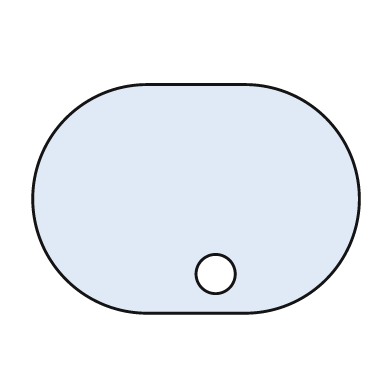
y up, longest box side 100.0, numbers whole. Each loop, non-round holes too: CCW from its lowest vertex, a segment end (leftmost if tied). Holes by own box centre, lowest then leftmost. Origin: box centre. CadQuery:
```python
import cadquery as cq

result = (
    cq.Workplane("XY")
    .moveTo(-15.0, -35.0)
    .lineTo(15.0, -35.0)
    .threePointArc((50.0, 0.0), (15.0, 35.0))
    .lineTo(-15.0, 35.0)
    .threePointArc((-50.0, 0.0), (-15.0, -35.0))
    .close()
    .moveTo(6.0, -23.0)
    .circle(6.0)
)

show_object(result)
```